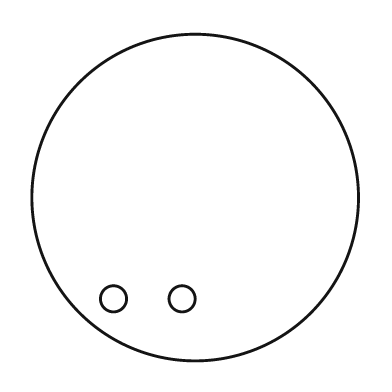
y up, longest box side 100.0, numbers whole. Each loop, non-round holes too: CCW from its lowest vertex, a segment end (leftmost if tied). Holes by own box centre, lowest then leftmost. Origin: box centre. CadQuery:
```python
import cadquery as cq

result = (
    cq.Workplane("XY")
    .moveTo(0.0, 0.0)
    .circle(50.0)
    .moveTo(-25.0, -31.0)
    .circle(4.0)
    .moveTo(-4.0, -31.0)
    .circle(4.0)
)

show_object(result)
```